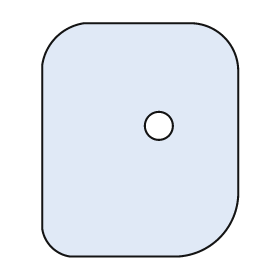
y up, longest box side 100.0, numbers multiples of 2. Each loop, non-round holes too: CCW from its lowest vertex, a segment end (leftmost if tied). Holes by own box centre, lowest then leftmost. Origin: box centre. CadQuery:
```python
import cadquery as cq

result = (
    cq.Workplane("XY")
    .moveTo(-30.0, -50.0)
    .lineTo(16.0, -50.0)
    .threePointArc((34.0, -42.0), (42.0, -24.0))
    .lineTo(42.0, 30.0)
    .threePointArc((36.0, 44.0), (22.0, 50.0))
    .lineTo(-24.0, 50.0)
    .threePointArc((-36.0, 44.0), (-42.0, 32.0))
    .lineTo(-42.0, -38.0)
    .threePointArc((-38.0, -46.0), (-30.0, -50.0))
    .close()
    .moveTo(8.0, 6.0)
    .circle(6.0)
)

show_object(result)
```